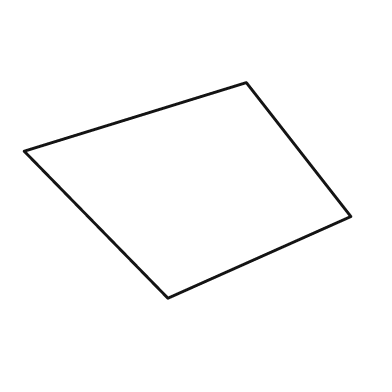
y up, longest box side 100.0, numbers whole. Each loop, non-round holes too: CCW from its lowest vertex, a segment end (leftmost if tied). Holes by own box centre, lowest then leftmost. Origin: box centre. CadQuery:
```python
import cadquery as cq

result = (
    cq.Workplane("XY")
    .moveTo(-6.0, -33.0)
    .lineTo(50.0, -8.0)
    .lineTo(18.0, 33.0)
    .lineTo(-50.0, 12.0)
    .close()
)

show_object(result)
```